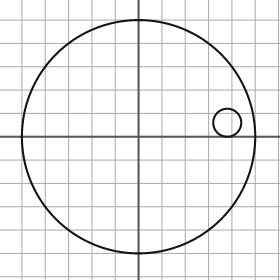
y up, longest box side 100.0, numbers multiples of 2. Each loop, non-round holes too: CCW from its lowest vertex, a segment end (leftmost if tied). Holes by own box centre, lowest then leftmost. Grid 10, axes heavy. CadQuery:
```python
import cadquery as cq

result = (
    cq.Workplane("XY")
    .moveTo(0.0, 0.0)
    .circle(50.0)
    .moveTo(38.0, 6.0)
    .circle(6.0)
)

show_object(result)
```